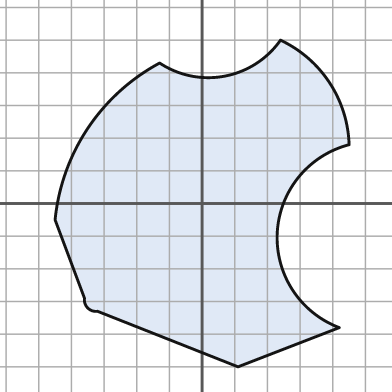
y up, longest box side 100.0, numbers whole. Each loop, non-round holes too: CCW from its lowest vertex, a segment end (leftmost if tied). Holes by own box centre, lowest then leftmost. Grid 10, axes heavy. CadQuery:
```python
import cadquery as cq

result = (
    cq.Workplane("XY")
    .moveTo(11.0, -50.0)
    .lineTo(42.0, -38.0)
    .threePointArc((23.0, -9.0), (45.0, 18.0))
    .threePointArc((39.0, 37.0), (24.0, 50.0))
    .threePointArc((7.0, 39.0), (-13.0, 43.0))
    .threePointArc((-35.0, 23.0), (-45.0, -5.0))
    .lineTo(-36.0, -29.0)
    .threePointArc((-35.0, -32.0), (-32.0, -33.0))
    .close()
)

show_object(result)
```